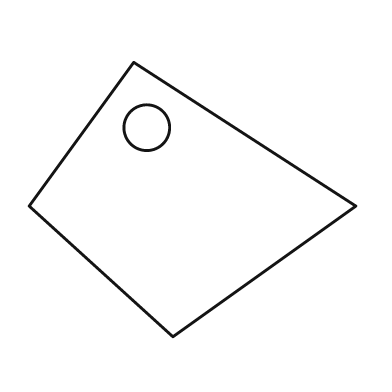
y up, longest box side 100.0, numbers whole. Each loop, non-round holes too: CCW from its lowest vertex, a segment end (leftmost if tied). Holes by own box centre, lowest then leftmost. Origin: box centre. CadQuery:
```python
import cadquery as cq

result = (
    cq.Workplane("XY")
    .moveTo(-6.0, -42.0)
    .lineTo(50.0, -2.0)
    .lineTo(-18.0, 42.0)
    .lineTo(-50.0, -2.0)
    .close()
    .moveTo(-14.0, 22.0)
    .circle(7.0)
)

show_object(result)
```